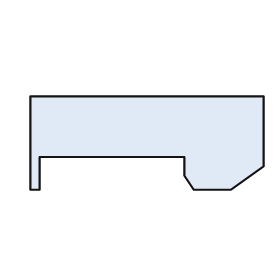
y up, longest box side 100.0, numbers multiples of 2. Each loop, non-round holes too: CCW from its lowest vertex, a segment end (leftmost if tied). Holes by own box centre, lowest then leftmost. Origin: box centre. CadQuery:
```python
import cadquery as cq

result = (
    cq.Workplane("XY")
    .moveTo(-50.0, -20.0)
    .lineTo(-46.0, -20.0)
    .lineTo(-46.0, -6.0)
    .lineTo(16.0, -6.0)
    .lineTo(16.0, -14.0)
    .lineTo(20.0, -20.0)
    .lineTo(36.0, -20.0)
    .lineTo(50.0, -10.0)
    .lineTo(50.0, 20.0)
    .lineTo(-50.0, 20.0)
    .close()
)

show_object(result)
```